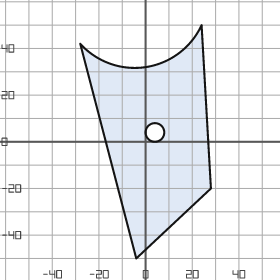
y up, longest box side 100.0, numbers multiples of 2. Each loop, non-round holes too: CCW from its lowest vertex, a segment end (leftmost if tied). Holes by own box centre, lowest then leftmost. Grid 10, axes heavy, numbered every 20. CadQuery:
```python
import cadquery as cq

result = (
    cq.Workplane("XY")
    .moveTo(-4.0, -50.0)
    .lineTo(28.0, -20.0)
    .lineTo(24.0, 50.0)
    .threePointArc((0.0, 32.0), (-28.0, 42.0))
    .close()
    .moveTo(4.0, 4.0)
    .circle(4.0)
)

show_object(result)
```